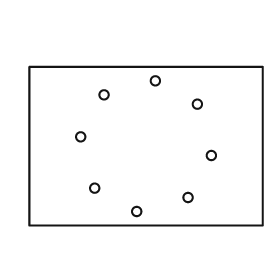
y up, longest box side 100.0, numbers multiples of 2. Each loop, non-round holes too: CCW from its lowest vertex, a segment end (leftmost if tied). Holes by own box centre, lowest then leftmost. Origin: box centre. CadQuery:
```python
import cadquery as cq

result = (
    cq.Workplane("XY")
    .moveTo(-50.0, -34.0)
    .lineTo(50.0, -34.0)
    .lineTo(50.0, 34.0)
    .lineTo(-50.0, 34.0)
    .close()
    .moveTo(-4.0, -28.0)
    .circle(2.0)
    .moveTo(18.0, -22.0)
    .circle(2.0)
    .moveTo(-22.0, -18.0)
    .circle(2.0)
    .moveTo(28.0, -4.0)
    .circle(2.0)
    .moveTo(-28.0, 4.0)
    .circle(2.0)
    .moveTo(22.0, 18.0)
    .circle(2.0)
    .moveTo(-18.0, 22.0)
    .circle(2.0)
    .moveTo(4.0, 28.0)
    .circle(2.0)
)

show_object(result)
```